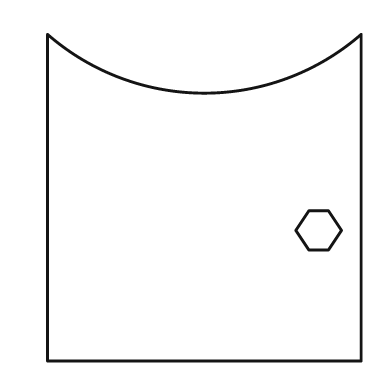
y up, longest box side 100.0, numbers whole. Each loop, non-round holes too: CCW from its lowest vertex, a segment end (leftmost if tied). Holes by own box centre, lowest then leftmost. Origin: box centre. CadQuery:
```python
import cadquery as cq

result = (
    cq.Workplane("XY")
    .moveTo(-48.0, -50.0)
    .lineTo(48.0, -50.0)
    .lineTo(48.0, 50.0)
    .threePointArc((0.0, 32.0), (-48.0, 50.0))
    .close()
    .moveTo(32.0, -16.0)
    .lineTo(38.0, -16.0)
    .lineTo(42.0, -10.0)
    .lineTo(38.0, -4.0)
    .lineTo(32.0, -4.0)
    .lineTo(28.0, -10.0)
    .close()
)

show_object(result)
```